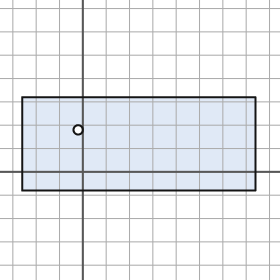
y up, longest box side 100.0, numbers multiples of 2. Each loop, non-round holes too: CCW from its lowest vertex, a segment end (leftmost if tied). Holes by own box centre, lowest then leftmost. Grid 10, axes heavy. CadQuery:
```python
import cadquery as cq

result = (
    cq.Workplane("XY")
    .moveTo(-26.0, -8.0)
    .lineTo(74.0, -8.0)
    .lineTo(74.0, 32.0)
    .lineTo(-26.0, 32.0)
    .close()
    .moveTo(-2.0, 18.0)
    .circle(2.0)
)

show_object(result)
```